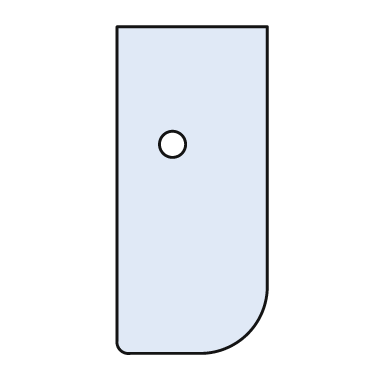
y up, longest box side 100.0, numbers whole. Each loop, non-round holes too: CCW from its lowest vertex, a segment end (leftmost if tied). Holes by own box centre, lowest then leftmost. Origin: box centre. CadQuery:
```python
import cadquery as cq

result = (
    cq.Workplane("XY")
    .moveTo(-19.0, -50.0)
    .lineTo(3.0, -50.0)
    .threePointArc((17.0, -44.0), (23.0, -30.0))
    .lineTo(23.0, 50.0)
    .lineTo(-23.0, 50.0)
    .lineTo(-23.0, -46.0)
    .threePointArc((-22.0, -49.0), (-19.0, -50.0))
    .close()
    .moveTo(-6.0, 14.0)
    .circle(4.0)
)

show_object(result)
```